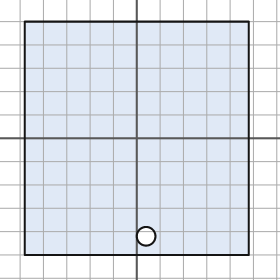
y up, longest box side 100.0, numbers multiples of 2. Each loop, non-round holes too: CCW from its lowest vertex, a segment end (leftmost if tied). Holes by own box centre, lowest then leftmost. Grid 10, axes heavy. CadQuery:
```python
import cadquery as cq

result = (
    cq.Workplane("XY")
    .moveTo(-48.0, -50.0)
    .lineTo(48.0, -50.0)
    .lineTo(48.0, 50.0)
    .lineTo(-48.0, 50.0)
    .close()
    .moveTo(4.0, -42.0)
    .circle(4.0)
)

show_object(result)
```